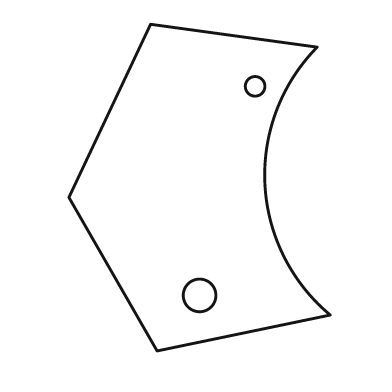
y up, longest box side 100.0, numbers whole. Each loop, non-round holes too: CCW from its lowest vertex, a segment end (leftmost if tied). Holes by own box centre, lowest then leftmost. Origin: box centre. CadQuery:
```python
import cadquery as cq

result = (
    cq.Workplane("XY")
    .moveTo(-13.0, -50.0)
    .lineTo(40.0, -39.0)
    .threePointArc((20.0, 1.0), (36.0, 43.0))
    .lineTo(-15.0, 50.0)
    .lineTo(-40.0, -3.0)
    .close()
    .moveTo(0.0, -33.0)
    .circle(5.0)
    .moveTo(17.0, 31.0)
    .circle(3.0)
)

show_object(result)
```